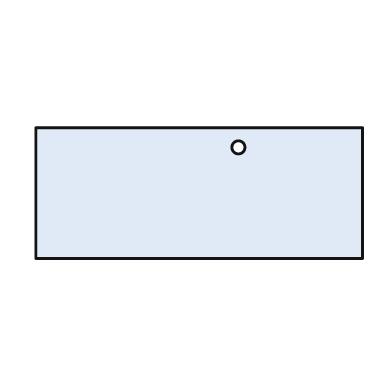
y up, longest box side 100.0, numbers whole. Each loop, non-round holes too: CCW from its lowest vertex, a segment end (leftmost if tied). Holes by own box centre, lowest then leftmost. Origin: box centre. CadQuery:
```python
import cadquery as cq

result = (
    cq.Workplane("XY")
    .moveTo(-50.0, -20.0)
    .lineTo(50.0, -20.0)
    .lineTo(50.0, 20.0)
    .lineTo(-50.0, 20.0)
    .close()
    .moveTo(12.0, 14.0)
    .circle(2.0)
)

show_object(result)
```